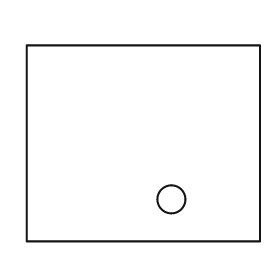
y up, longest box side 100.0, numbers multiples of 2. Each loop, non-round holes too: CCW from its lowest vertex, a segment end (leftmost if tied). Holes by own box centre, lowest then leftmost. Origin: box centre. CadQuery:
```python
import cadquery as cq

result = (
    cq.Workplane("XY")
    .moveTo(-50.0, -42.0)
    .lineTo(50.0, -42.0)
    .lineTo(50.0, 42.0)
    .lineTo(-50.0, 42.0)
    .close()
    .moveTo(12.0, -24.0)
    .circle(6.0)
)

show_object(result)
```